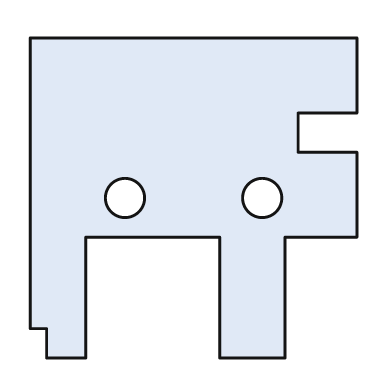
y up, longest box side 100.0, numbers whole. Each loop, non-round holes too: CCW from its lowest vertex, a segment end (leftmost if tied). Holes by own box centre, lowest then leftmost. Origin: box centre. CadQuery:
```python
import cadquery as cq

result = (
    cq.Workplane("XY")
    .moveTo(-45.0, -49.0)
    .lineTo(-33.0, -49.0)
    .lineTo(-33.0, -12.0)
    .lineTo(8.0, -12.0)
    .lineTo(8.0, -49.0)
    .lineTo(28.0, -49.0)
    .lineTo(28.0, -12.0)
    .lineTo(50.0, -12.0)
    .lineTo(50.0, 14.0)
    .lineTo(32.0, 14.0)
    .lineTo(32.0, 26.0)
    .lineTo(50.0, 26.0)
    .lineTo(50.0, 49.0)
    .lineTo(-50.0, 49.0)
    .lineTo(-50.0, -40.0)
    .lineTo(-45.0, -40.0)
    .close()
    .moveTo(-21.0, 0.0)
    .circle(6.0)
    .moveTo(21.0, 0.0)
    .circle(6.0)
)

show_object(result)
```